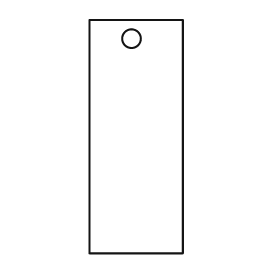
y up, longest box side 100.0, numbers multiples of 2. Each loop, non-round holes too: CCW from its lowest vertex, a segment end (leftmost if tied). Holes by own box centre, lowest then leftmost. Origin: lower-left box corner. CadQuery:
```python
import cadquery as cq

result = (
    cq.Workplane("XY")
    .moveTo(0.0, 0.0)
    .lineTo(40.0, 0.0)
    .lineTo(40.0, 100.0)
    .lineTo(0.0, 100.0)
    .close()
    .moveTo(18.0, 92.0)
    .circle(4.0)
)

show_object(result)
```